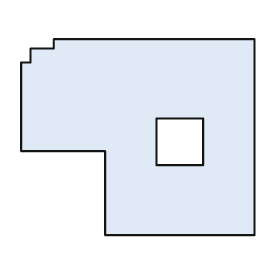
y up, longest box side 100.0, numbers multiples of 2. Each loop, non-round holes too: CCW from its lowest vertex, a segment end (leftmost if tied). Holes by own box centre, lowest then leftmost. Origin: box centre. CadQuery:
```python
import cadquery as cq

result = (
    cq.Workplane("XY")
    .moveTo(-14.0, -42.0)
    .lineTo(50.0, -42.0)
    .lineTo(50.0, 42.0)
    .lineTo(-36.0, 42.0)
    .lineTo(-36.0, 38.0)
    .lineTo(-46.0, 38.0)
    .lineTo(-46.0, 32.0)
    .lineTo(-50.0, 32.0)
    .lineTo(-50.0, -6.0)
    .lineTo(-14.0, -6.0)
    .close()
    .moveTo(8.0, -12.0)
    .lineTo(28.0, -12.0)
    .lineTo(28.0, 8.0)
    .lineTo(8.0, 8.0)
    .close()
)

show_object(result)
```